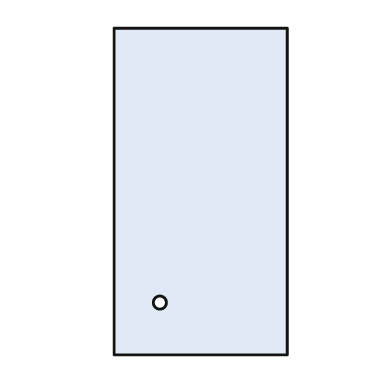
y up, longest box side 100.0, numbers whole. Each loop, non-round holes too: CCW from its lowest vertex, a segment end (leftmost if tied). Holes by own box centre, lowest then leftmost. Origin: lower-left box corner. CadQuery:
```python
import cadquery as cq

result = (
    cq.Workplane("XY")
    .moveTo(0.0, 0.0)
    .lineTo(53.0, 0.0)
    .lineTo(53.0, 100.0)
    .lineTo(0.0, 100.0)
    .close()
    .moveTo(14.0, 16.0)
    .circle(2.0)
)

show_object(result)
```